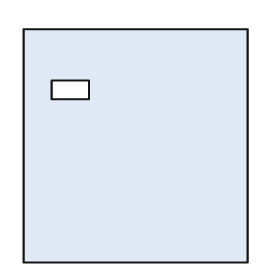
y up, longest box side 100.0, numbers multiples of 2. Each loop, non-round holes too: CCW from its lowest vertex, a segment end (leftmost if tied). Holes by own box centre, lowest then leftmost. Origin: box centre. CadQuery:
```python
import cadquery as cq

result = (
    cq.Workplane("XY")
    .moveTo(-48.0, -50.0)
    .lineTo(48.0, -50.0)
    .lineTo(48.0, 50.0)
    .lineTo(-48.0, 50.0)
    .close()
    .moveTo(-36.0, 20.0)
    .lineTo(-20.0, 20.0)
    .lineTo(-20.0, 28.0)
    .lineTo(-36.0, 28.0)
    .close()
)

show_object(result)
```